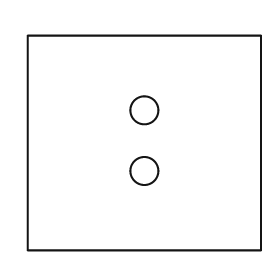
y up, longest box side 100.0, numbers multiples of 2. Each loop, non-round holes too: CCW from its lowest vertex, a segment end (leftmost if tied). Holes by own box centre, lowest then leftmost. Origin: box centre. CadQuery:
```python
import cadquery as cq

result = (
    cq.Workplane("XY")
    .moveTo(-50.0, -46.0)
    .lineTo(50.0, -46.0)
    .lineTo(50.0, 46.0)
    .lineTo(-50.0, 46.0)
    .close()
    .moveTo(0.0, -12.0)
    .circle(6.0)
    .moveTo(0.0, 14.0)
    .circle(6.0)
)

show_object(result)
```